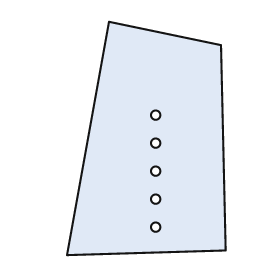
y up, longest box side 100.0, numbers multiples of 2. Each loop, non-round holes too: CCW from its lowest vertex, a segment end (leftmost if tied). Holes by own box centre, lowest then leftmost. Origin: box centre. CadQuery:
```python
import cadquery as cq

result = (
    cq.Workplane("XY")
    .moveTo(-34.0, -50.0)
    .lineTo(34.0, -48.0)
    .lineTo(32.0, 40.0)
    .lineTo(-16.0, 50.0)
    .close()
    .moveTo(4.0, -38.0)
    .circle(2.0)
    .moveTo(4.0, -26.0)
    .circle(2.0)
    .moveTo(4.0, -14.0)
    .circle(2.0)
    .moveTo(4.0, -2.0)
    .circle(2.0)
    .moveTo(4.0, 10.0)
    .circle(2.0)
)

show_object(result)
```